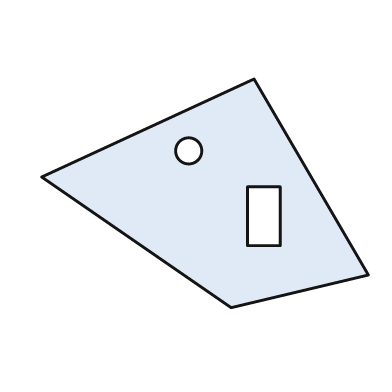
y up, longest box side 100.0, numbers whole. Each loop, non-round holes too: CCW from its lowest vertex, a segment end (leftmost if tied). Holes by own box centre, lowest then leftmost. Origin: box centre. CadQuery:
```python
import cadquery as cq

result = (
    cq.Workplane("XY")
    .moveTo(8.0, -35.0)
    .lineTo(50.0, -25.0)
    .lineTo(15.0, 35.0)
    .lineTo(-50.0, 5.0)
    .close()
    .moveTo(13.0, -16.0)
    .lineTo(23.0, -16.0)
    .lineTo(23.0, 2.0)
    .lineTo(13.0, 2.0)
    .close()
    .moveTo(-5.0, 13.0)
    .circle(4.0)
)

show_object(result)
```